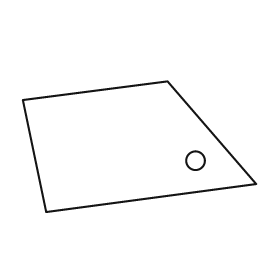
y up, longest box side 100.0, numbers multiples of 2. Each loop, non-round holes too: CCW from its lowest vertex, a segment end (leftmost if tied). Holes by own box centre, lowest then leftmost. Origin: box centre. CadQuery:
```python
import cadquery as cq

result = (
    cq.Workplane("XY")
    .moveTo(-40.0, -28.0)
    .lineTo(50.0, -16.0)
    .lineTo(12.0, 28.0)
    .lineTo(-50.0, 20.0)
    .close()
    .moveTo(24.0, -6.0)
    .circle(4.0)
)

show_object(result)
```